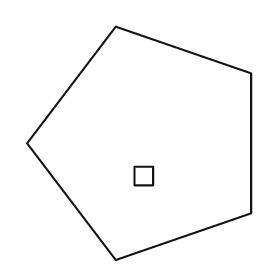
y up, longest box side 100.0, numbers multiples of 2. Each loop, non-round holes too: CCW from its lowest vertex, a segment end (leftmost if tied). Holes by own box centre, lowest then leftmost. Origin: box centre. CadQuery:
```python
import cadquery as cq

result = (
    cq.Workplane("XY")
    .moveTo(-10.0, -50.0)
    .lineTo(48.0, -30.0)
    .lineTo(48.0, 30.0)
    .lineTo(-10.0, 50.0)
    .lineTo(-48.0, 0.0)
    .close()
    .moveTo(-2.0, -18.0)
    .lineTo(6.0, -18.0)
    .lineTo(6.0, -10.0)
    .lineTo(-2.0, -10.0)
    .close()
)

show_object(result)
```